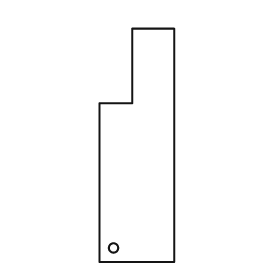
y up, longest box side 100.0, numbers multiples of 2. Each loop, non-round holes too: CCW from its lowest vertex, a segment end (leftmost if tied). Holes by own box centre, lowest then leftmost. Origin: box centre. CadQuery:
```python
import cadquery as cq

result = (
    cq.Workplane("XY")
    .moveTo(-16.0, -50.0)
    .lineTo(16.0, -50.0)
    .lineTo(16.0, 50.0)
    .lineTo(-2.0, 50.0)
    .lineTo(-2.0, 18.0)
    .lineTo(-16.0, 18.0)
    .close()
    .moveTo(-10.0, -44.0)
    .circle(2.0)
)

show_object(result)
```